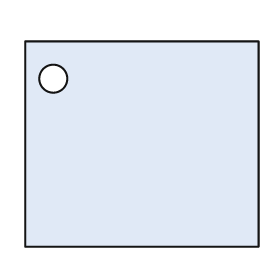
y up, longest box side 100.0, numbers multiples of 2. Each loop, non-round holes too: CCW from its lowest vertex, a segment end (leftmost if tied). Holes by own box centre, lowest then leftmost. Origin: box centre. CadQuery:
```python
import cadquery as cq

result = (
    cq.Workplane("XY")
    .moveTo(-50.0, -44.0)
    .lineTo(50.0, -44.0)
    .lineTo(50.0, 44.0)
    .lineTo(-50.0, 44.0)
    .close()
    .moveTo(-38.0, 28.0)
    .circle(6.0)
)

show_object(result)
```